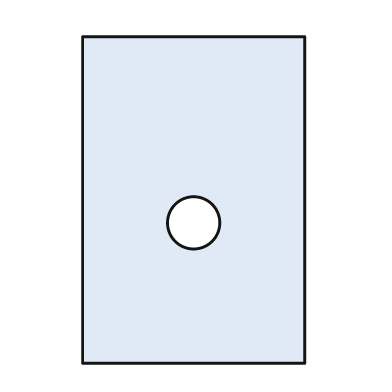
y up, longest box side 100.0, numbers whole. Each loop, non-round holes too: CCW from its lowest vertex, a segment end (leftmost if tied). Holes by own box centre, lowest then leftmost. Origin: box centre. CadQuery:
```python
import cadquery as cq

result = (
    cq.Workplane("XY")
    .moveTo(-34.0, -50.0)
    .lineTo(34.0, -50.0)
    .lineTo(34.0, 50.0)
    .lineTo(-34.0, 50.0)
    .close()
    .moveTo(0.0, -7.0)
    .circle(8.0)
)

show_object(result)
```